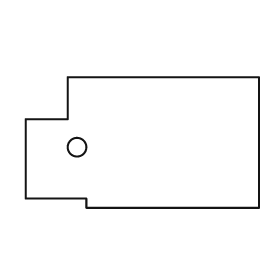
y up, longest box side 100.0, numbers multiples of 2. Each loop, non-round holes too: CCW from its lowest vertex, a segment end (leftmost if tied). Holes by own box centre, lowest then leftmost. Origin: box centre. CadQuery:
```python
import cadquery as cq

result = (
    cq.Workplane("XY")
    .moveTo(-24.0, -28.0)
    .lineTo(50.0, -28.0)
    .lineTo(50.0, 28.0)
    .lineTo(-32.0, 28.0)
    .lineTo(-32.0, 10.0)
    .lineTo(-50.0, 10.0)
    .lineTo(-50.0, -24.0)
    .lineTo(-24.0, -24.0)
    .close()
    .moveTo(-28.0, -2.0)
    .circle(4.0)
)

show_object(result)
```